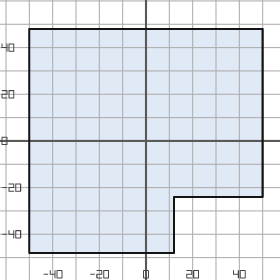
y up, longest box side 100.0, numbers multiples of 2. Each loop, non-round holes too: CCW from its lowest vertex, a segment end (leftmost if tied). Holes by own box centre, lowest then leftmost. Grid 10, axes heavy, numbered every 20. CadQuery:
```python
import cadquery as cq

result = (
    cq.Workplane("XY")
    .moveTo(-50.0, -48.0)
    .lineTo(12.0, -48.0)
    .lineTo(12.0, -24.0)
    .lineTo(50.0, -24.0)
    .lineTo(50.0, 48.0)
    .lineTo(-50.0, 48.0)
    .close()
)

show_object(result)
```